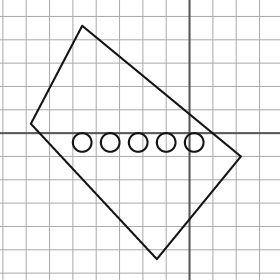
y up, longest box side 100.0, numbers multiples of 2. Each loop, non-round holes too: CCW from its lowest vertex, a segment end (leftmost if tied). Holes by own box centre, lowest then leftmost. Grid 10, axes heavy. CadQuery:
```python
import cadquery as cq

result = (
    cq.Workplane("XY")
    .moveTo(-14.0, -54.0)
    .lineTo(22.0, -10.0)
    .lineTo(-46.0, 46.0)
    .lineTo(-68.0, 4.0)
    .close()
    .moveTo(-46.0, -4.0)
    .circle(4.0)
    .moveTo(-34.0, -4.0)
    .circle(4.0)
    .moveTo(-22.0, -4.0)
    .circle(4.0)
    .moveTo(-10.0, -4.0)
    .circle(4.0)
    .moveTo(2.0, -4.0)
    .circle(4.0)
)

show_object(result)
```